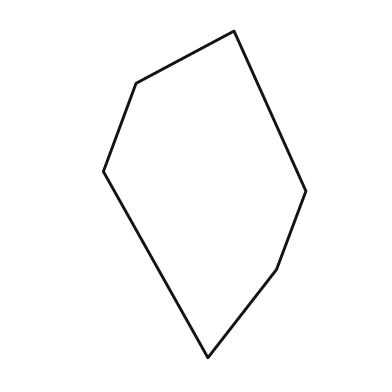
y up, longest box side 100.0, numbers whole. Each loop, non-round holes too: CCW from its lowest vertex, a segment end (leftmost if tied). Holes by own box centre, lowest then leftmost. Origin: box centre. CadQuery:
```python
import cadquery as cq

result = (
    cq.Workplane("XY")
    .moveTo(1.0, -50.0)
    .lineTo(22.0, -23.0)
    .lineTo(31.0, 1.0)
    .lineTo(9.0, 50.0)
    .lineTo(-21.0, 34.0)
    .lineTo(-31.0, 7.0)
    .close()
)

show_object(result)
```